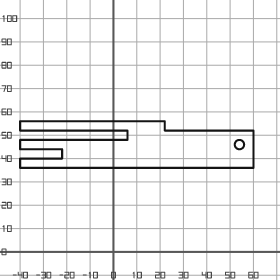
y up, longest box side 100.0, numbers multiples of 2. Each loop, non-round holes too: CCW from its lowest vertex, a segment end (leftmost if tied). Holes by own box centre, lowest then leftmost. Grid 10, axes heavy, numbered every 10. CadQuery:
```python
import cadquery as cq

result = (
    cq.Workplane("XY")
    .moveTo(-40.0, 36.0)
    .lineTo(60.0, 36.0)
    .lineTo(60.0, 52.0)
    .lineTo(22.0, 52.0)
    .lineTo(22.0, 56.0)
    .lineTo(-40.0, 56.0)
    .lineTo(-40.0, 52.0)
    .lineTo(6.0, 52.0)
    .lineTo(6.0, 48.0)
    .lineTo(-40.0, 48.0)
    .lineTo(-40.0, 44.0)
    .lineTo(-22.0, 44.0)
    .lineTo(-22.0, 40.0)
    .lineTo(-40.0, 40.0)
    .close()
    .moveTo(54.0, 46.0)
    .circle(2.0)
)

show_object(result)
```